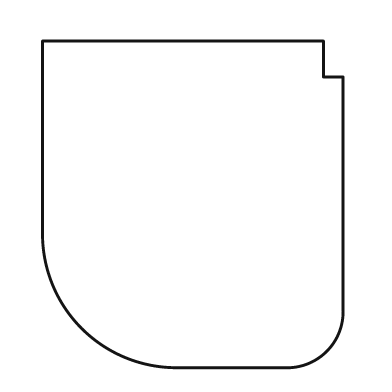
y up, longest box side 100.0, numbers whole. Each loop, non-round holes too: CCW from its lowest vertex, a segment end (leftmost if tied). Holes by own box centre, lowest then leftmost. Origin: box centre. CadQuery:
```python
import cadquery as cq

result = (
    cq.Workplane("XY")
    .moveTo(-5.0, -50.0)
    .lineTo(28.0, -50.0)
    .threePointArc((41.0, -45.0), (46.0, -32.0))
    .lineTo(46.0, 39.0)
    .lineTo(40.0, 39.0)
    .lineTo(40.0, 50.0)
    .lineTo(-46.0, 50.0)
    .lineTo(-46.0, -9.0)
    .threePointArc((-34.0, -38.0), (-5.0, -50.0))
    .close()
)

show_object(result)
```